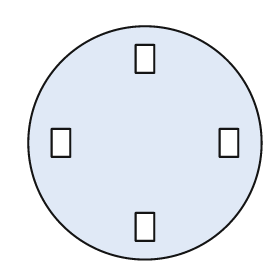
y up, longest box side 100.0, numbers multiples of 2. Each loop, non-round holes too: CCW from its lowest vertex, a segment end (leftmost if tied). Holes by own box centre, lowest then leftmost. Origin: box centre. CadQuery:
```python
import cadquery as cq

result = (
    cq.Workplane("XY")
    .moveTo(0.0, 0.0)
    .circle(50.0)
    .moveTo(-4.0, -42.0)
    .lineTo(4.0, -42.0)
    .lineTo(4.0, -30.0)
    .lineTo(-4.0, -30.0)
    .close()
    .moveTo(-40.0, -6.0)
    .lineTo(-32.0, -6.0)
    .lineTo(-32.0, 6.0)
    .lineTo(-40.0, 6.0)
    .close()
    .moveTo(32.0, -6.0)
    .lineTo(40.0, -6.0)
    .lineTo(40.0, 6.0)
    .lineTo(32.0, 6.0)
    .close()
    .moveTo(-4.0, 30.0)
    .lineTo(4.0, 30.0)
    .lineTo(4.0, 42.0)
    .lineTo(-4.0, 42.0)
    .close()
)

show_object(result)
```